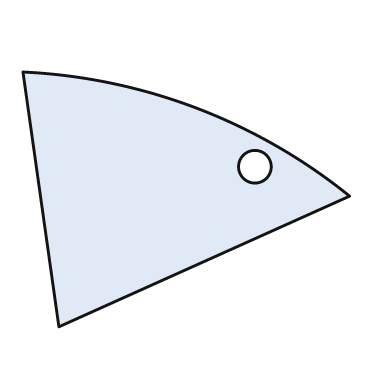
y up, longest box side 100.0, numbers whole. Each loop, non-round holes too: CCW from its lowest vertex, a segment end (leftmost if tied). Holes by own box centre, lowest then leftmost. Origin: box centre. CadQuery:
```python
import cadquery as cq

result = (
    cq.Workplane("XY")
    .moveTo(-39.0, -39.0)
    .lineTo(50.0, 1.0)
    .threePointArc((3.0, 28.0), (-50.0, 39.0))
    .close()
    .moveTo(21.0, 10.0)
    .circle(5.0)
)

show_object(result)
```